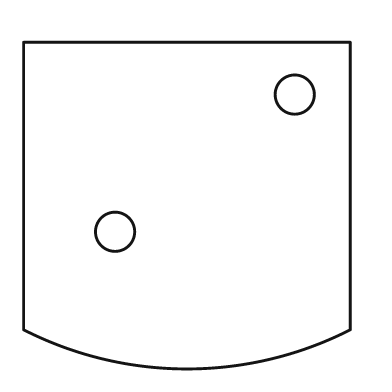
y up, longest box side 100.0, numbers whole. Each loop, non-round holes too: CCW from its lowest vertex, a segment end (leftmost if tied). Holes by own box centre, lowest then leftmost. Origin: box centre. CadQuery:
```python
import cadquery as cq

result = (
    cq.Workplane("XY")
    .moveTo(-50.0, -38.0)
    .threePointArc((0.0, -50.0), (50.0, -38.0))
    .lineTo(50.0, 50.0)
    .lineTo(-50.0, 50.0)
    .close()
    .moveTo(-22.0, -8.0)
    .circle(6.0)
    .moveTo(33.0, 34.0)
    .circle(6.0)
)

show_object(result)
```